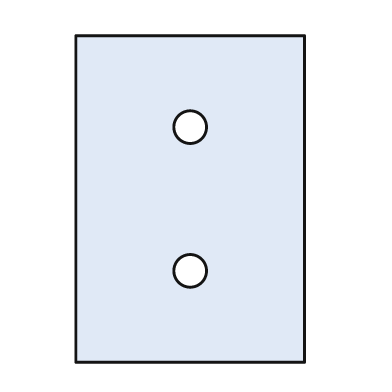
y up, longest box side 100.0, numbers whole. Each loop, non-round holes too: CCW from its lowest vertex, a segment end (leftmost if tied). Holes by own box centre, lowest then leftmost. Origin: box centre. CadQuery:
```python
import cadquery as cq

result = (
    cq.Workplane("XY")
    .moveTo(-35.0, -50.0)
    .lineTo(35.0, -50.0)
    .lineTo(35.0, 50.0)
    .lineTo(-35.0, 50.0)
    .close()
    .moveTo(0.0, -22.0)
    .circle(5.0)
    .moveTo(0.0, 22.0)
    .circle(5.0)
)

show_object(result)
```